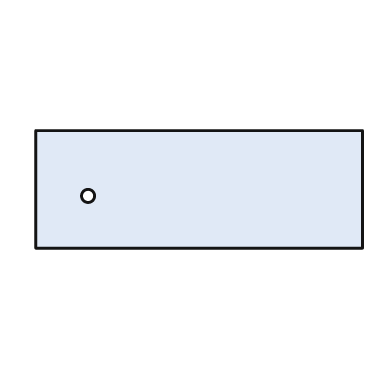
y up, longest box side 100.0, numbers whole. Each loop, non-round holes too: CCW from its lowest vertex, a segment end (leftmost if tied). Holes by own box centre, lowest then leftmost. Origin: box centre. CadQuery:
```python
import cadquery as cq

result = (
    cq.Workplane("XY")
    .moveTo(-50.0, -18.0)
    .lineTo(50.0, -18.0)
    .lineTo(50.0, 18.0)
    .lineTo(-50.0, 18.0)
    .close()
    .moveTo(-34.0, -2.0)
    .circle(2.0)
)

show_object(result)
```